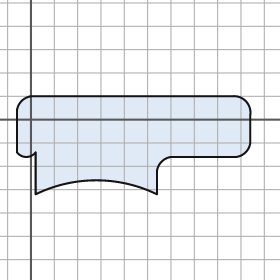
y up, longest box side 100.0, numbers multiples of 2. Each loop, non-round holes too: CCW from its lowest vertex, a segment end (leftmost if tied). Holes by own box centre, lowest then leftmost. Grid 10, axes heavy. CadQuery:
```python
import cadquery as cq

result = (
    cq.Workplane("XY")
    .moveTo(2.0, -32.0)
    .threePointArc((28.0, -26.0), (54.0, -32.0))
    .lineTo(54.0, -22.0)
    .threePointArc((56.0, -18.0), (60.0, -16.0))
    .lineTo(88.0, -16.0)
    .threePointArc((92.0, -14.0), (94.0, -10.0))
    .lineTo(94.0, 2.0)
    .threePointArc((92.0, 8.0), (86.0, 10.0))
    .lineTo(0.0, 10.0)
    .threePointArc((-4.0, 8.0), (-6.0, 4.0))
    .lineTo(-6.0, -14.0)
    .threePointArc((-2.0, -16.0), (2.0, -14.0))
    .close()
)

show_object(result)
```